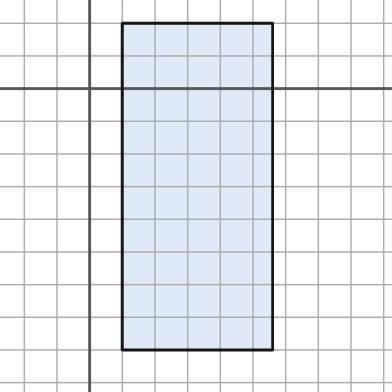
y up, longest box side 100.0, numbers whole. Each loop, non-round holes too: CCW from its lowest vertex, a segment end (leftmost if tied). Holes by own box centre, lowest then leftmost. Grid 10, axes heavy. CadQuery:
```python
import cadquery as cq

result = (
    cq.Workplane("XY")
    .moveTo(10.0, -80.0)
    .lineTo(56.0, -80.0)
    .lineTo(56.0, 20.0)
    .lineTo(10.0, 20.0)
    .close()
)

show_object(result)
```